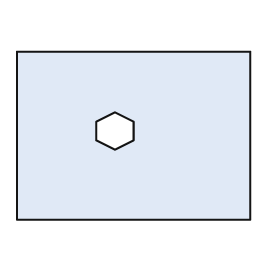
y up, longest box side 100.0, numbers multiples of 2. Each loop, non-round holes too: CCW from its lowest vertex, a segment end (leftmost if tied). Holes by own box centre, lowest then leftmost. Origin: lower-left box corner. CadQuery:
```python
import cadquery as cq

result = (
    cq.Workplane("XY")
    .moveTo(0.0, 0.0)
    .lineTo(100.0, 0.0)
    .lineTo(100.0, 72.0)
    .lineTo(0.0, 72.0)
    .close()
    .moveTo(42.0, 30.0)
    .lineTo(50.0, 34.0)
    .lineTo(50.0, 42.0)
    .lineTo(42.0, 46.0)
    .lineTo(34.0, 42.0)
    .lineTo(34.0, 34.0)
    .close()
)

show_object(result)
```